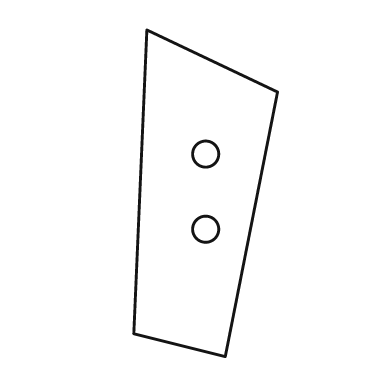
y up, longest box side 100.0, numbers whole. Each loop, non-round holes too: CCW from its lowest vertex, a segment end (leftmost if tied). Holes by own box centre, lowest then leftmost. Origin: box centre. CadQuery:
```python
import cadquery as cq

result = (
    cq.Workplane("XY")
    .moveTo(6.0, -50.0)
    .lineTo(22.0, 31.0)
    .lineTo(-18.0, 50.0)
    .lineTo(-22.0, -43.0)
    .close()
    .moveTo(0.0, -11.0)
    .circle(4.0)
    .moveTo(0.0, 12.0)
    .circle(4.0)
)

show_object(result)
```